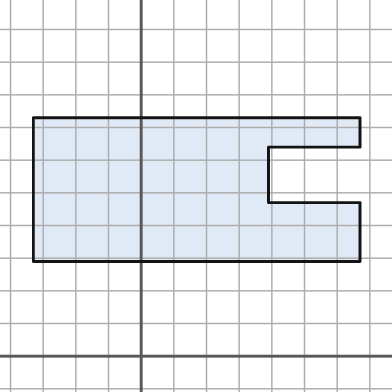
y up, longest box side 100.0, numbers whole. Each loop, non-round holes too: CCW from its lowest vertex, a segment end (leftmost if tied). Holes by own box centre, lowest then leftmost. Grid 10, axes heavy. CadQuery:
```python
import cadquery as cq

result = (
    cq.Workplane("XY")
    .moveTo(-33.0, 29.0)
    .lineTo(67.0, 29.0)
    .lineTo(67.0, 47.0)
    .lineTo(39.0, 47.0)
    .lineTo(39.0, 64.0)
    .lineTo(67.0, 64.0)
    .lineTo(67.0, 73.0)
    .lineTo(-33.0, 73.0)
    .close()
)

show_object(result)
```